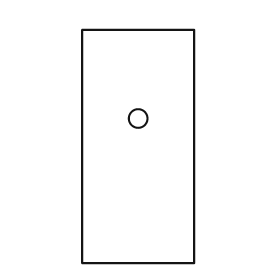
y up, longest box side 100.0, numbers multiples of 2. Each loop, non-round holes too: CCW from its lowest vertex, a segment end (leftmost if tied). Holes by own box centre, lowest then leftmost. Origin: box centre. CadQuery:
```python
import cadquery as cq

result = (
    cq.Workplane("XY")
    .moveTo(-24.0, -50.0)
    .lineTo(24.0, -50.0)
    .lineTo(24.0, 50.0)
    .lineTo(-24.0, 50.0)
    .close()
    .moveTo(0.0, 12.0)
    .circle(4.0)
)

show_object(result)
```